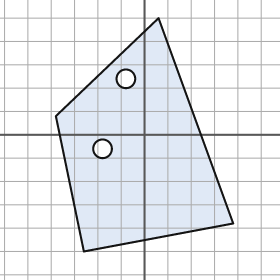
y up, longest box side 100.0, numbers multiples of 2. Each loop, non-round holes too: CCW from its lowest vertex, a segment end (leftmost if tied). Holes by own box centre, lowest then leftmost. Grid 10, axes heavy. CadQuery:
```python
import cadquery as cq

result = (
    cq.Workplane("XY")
    .moveTo(-26.0, -50.0)
    .lineTo(38.0, -38.0)
    .lineTo(6.0, 50.0)
    .lineTo(-38.0, 8.0)
    .close()
    .moveTo(-18.0, -6.0)
    .circle(4.0)
    .moveTo(-8.0, 24.0)
    .circle(4.0)
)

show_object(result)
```